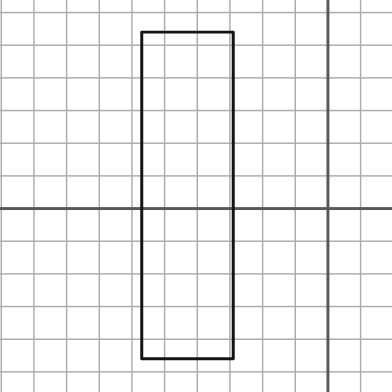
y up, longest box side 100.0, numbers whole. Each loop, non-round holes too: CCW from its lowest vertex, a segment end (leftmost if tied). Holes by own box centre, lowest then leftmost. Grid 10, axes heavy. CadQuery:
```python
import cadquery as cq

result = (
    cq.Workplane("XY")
    .moveTo(-57.0, -46.0)
    .lineTo(-29.0, -46.0)
    .lineTo(-29.0, 54.0)
    .lineTo(-57.0, 54.0)
    .close()
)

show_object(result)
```